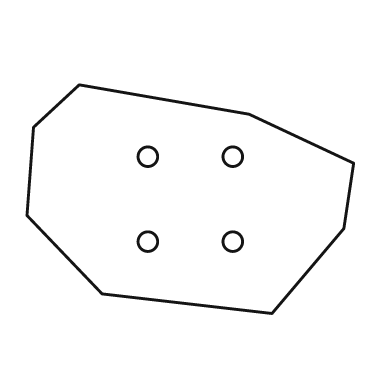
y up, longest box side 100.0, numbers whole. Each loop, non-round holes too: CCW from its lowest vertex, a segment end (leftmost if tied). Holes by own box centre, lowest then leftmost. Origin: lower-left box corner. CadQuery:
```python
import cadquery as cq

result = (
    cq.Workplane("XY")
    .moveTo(75.0, 0.0)
    .lineTo(97.0, 26.0)
    .lineTo(100.0, 46.0)
    .lineTo(68.0, 61.0)
    .lineTo(16.0, 70.0)
    .lineTo(2.0, 57.0)
    .lineTo(0.0, 30.0)
    .lineTo(23.0, 6.0)
    .close()
    .moveTo(37.0, 22.0)
    .circle(3.0)
    .moveTo(63.0, 22.0)
    .circle(3.0)
    .moveTo(37.0, 48.0)
    .circle(3.0)
    .moveTo(63.0, 48.0)
    .circle(3.0)
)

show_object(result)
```